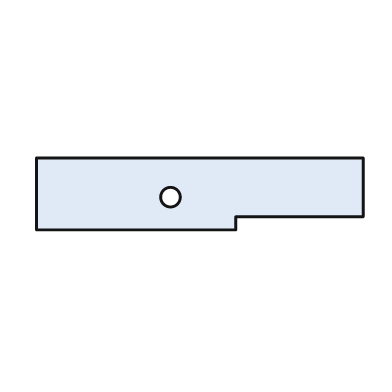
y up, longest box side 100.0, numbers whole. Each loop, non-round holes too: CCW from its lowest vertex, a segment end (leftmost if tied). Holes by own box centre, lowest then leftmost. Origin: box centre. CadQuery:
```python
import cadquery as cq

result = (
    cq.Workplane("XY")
    .moveTo(-50.0, -11.0)
    .lineTo(11.0, -11.0)
    .lineTo(11.0, -7.0)
    .lineTo(50.0, -7.0)
    .lineTo(50.0, 11.0)
    .lineTo(-50.0, 11.0)
    .close()
    .moveTo(-9.0, -1.0)
    .circle(3.0)
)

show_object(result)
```